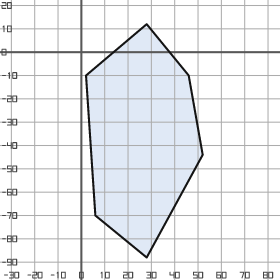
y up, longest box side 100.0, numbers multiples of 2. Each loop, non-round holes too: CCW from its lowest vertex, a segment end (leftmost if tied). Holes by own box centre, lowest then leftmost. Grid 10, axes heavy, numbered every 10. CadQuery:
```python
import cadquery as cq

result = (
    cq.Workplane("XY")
    .moveTo(28.0, -88.0)
    .lineTo(52.0, -44.0)
    .lineTo(46.0, -10.0)
    .lineTo(28.0, 12.0)
    .lineTo(2.0, -10.0)
    .lineTo(6.0, -70.0)
    .close()
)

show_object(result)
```